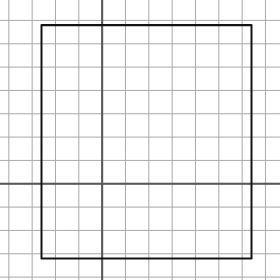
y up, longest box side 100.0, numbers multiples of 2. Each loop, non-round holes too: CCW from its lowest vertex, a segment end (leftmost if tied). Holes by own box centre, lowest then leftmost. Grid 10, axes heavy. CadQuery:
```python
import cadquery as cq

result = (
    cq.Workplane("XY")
    .moveTo(-26.0, -32.0)
    .lineTo(64.0, -32.0)
    .lineTo(64.0, 68.0)
    .lineTo(-26.0, 68.0)
    .close()
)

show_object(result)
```